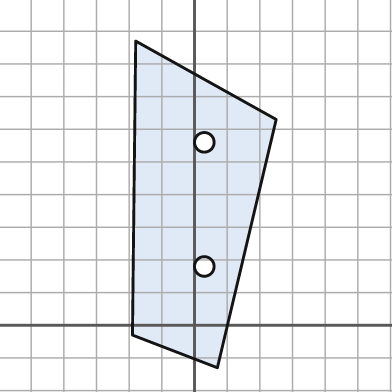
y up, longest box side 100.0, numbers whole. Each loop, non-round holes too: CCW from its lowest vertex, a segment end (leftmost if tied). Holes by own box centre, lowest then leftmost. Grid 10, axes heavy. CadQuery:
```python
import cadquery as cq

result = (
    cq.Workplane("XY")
    .moveTo(7.0, -13.0)
    .lineTo(25.0, 63.0)
    .lineTo(-18.0, 87.0)
    .lineTo(-19.0, -3.0)
    .close()
    .moveTo(3.0, 18.0)
    .circle(3.0)
    .moveTo(3.0, 56.0)
    .circle(3.0)
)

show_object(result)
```